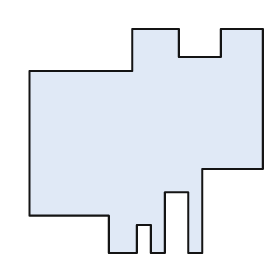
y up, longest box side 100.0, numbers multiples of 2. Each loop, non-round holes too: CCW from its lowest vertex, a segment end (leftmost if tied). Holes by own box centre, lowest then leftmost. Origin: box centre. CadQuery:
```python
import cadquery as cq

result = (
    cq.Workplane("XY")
    .moveTo(-16.0, -48.0)
    .lineTo(-4.0, -48.0)
    .lineTo(-4.0, -36.0)
    .lineTo(2.0, -36.0)
    .lineTo(2.0, -48.0)
    .lineTo(8.0, -48.0)
    .lineTo(8.0, -22.0)
    .lineTo(18.0, -22.0)
    .lineTo(18.0, -48.0)
    .lineTo(24.0, -48.0)
    .lineTo(24.0, -12.0)
    .lineTo(50.0, -12.0)
    .lineTo(50.0, 48.0)
    .lineTo(32.0, 48.0)
    .lineTo(32.0, 36.0)
    .lineTo(14.0, 36.0)
    .lineTo(14.0, 48.0)
    .lineTo(-6.0, 48.0)
    .lineTo(-6.0, 30.0)
    .lineTo(-50.0, 30.0)
    .lineTo(-50.0, -32.0)
    .lineTo(-16.0, -32.0)
    .close()
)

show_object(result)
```